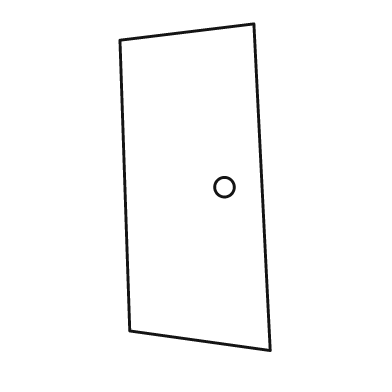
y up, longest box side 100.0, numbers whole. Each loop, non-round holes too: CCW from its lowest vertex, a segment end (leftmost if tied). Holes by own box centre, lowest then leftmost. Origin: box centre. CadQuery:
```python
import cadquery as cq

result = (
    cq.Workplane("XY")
    .moveTo(23.0, -50.0)
    .lineTo(18.0, 50.0)
    .lineTo(-23.0, 45.0)
    .lineTo(-20.0, -44.0)
    .close()
    .moveTo(9.0, 0.0)
    .circle(3.0)
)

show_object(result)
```